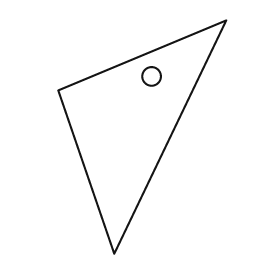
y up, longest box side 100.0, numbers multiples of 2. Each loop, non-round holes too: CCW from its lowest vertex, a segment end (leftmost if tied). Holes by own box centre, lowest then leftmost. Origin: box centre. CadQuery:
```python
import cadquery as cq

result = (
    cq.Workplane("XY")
    .moveTo(-12.0, -50.0)
    .lineTo(36.0, 50.0)
    .lineTo(-36.0, 20.0)
    .close()
    .moveTo(4.0, 26.0)
    .circle(4.0)
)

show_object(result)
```